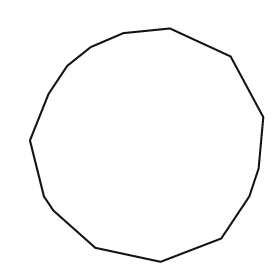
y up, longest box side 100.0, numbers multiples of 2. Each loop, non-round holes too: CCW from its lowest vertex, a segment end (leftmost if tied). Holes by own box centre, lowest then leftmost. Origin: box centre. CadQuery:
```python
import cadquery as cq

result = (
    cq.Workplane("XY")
    .moveTo(6.0, -50.0)
    .lineTo(32.0, -40.0)
    .lineTo(44.0, -22.0)
    .lineTo(48.0, -10.0)
    .lineTo(50.0, 12.0)
    .lineTo(36.0, 38.0)
    .lineTo(10.0, 50.0)
    .lineTo(-10.0, 48.0)
    .lineTo(-24.0, 42.0)
    .lineTo(-34.0, 34.0)
    .lineTo(-42.0, 22.0)
    .lineTo(-50.0, 2.0)
    .lineTo(-44.0, -22.0)
    .lineTo(-40.0, -28.0)
    .lineTo(-22.0, -44.0)
    .close()
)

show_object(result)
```